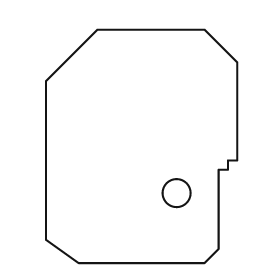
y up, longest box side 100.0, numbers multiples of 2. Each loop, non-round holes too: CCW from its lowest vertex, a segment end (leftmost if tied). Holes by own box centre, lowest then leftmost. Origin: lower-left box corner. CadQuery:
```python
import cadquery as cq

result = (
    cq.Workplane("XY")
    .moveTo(14.0, 0.0)
    .lineTo(68.0, 0.0)
    .lineTo(74.0, 6.0)
    .lineTo(74.0, 40.0)
    .lineTo(78.0, 40.0)
    .lineTo(78.0, 44.0)
    .lineTo(82.0, 44.0)
    .lineTo(82.0, 86.0)
    .lineTo(68.0, 100.0)
    .lineTo(22.0, 100.0)
    .lineTo(0.0, 78.0)
    .lineTo(0.0, 10.0)
    .close()
    .moveTo(56.0, 30.0)
    .circle(6.0)
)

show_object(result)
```